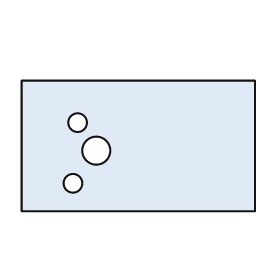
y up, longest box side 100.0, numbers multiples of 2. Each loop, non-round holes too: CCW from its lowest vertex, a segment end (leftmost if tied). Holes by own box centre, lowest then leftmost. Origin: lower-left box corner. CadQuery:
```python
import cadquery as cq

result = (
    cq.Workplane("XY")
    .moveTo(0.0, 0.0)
    .lineTo(100.0, 0.0)
    .lineTo(100.0, 56.0)
    .lineTo(0.0, 56.0)
    .close()
    .moveTo(22.0, 12.0)
    .circle(4.0)
    .moveTo(32.0, 26.0)
    .circle(6.0)
    .moveTo(24.0, 38.0)
    .circle(4.0)
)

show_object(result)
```